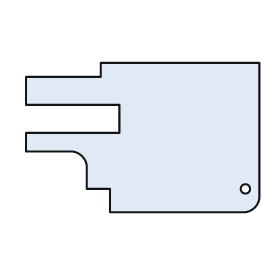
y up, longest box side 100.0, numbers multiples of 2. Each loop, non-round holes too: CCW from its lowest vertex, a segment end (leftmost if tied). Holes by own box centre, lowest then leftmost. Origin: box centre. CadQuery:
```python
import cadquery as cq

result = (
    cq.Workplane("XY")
    .moveTo(-14.0, -32.0)
    .lineTo(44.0, -32.0)
    .threePointArc((48.0, -30.0), (50.0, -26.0))
    .lineTo(50.0, 32.0)
    .lineTo(-18.0, 32.0)
    .lineTo(-18.0, 26.0)
    .lineTo(-50.0, 26.0)
    .lineTo(-50.0, 14.0)
    .lineTo(-10.0, 14.0)
    .lineTo(-10.0, 2.0)
    .lineTo(-50.0, 2.0)
    .lineTo(-50.0, -6.0)
    .lineTo(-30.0, -6.0)
    .threePointArc((-26.0, -8.0), (-24.0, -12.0))
    .lineTo(-24.0, -22.0)
    .lineTo(-14.0, -22.0)
    .close()
    .moveTo(44.0, -22.0)
    .circle(2.0)
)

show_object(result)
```